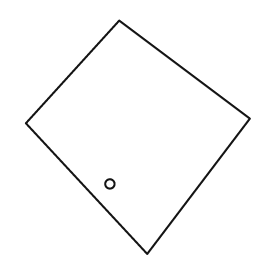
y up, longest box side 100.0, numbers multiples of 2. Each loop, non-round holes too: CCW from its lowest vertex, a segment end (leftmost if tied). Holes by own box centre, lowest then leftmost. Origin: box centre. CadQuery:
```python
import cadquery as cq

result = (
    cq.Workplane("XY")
    .moveTo(4.0, -50.0)
    .lineTo(48.0, 8.0)
    .lineTo(-8.0, 50.0)
    .lineTo(-48.0, 6.0)
    .close()
    .moveTo(-12.0, -20.0)
    .circle(2.0)
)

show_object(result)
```